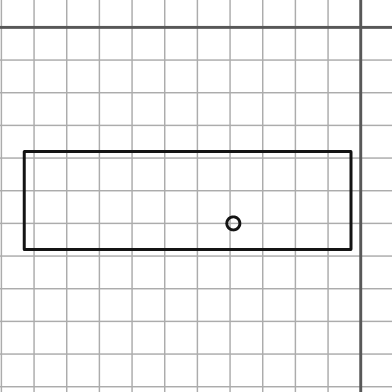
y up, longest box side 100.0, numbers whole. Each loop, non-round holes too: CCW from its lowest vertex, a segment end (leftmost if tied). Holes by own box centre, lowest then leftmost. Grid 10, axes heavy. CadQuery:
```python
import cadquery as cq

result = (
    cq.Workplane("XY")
    .moveTo(-103.0, -68.0)
    .lineTo(-3.0, -68.0)
    .lineTo(-3.0, -38.0)
    .lineTo(-103.0, -38.0)
    .close()
    .moveTo(-39.0, -60.0)
    .circle(2.0)
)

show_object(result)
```